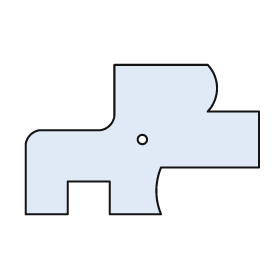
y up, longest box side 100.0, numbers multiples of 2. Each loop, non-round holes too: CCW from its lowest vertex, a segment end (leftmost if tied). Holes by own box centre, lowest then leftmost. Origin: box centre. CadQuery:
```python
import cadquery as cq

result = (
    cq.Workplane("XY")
    .moveTo(-50.0, -32.0)
    .lineTo(-32.0, -32.0)
    .lineTo(-32.0, -18.0)
    .lineTo(-14.0, -18.0)
    .lineTo(-14.0, -32.0)
    .lineTo(8.0, -32.0)
    .threePointArc((6.0, -22.0), (8.0, -12.0))
    .lineTo(50.0, -12.0)
    .lineTo(50.0, 12.0)
    .lineTo(28.0, 12.0)
    .threePointArc((32.0, 22.0), (28.0, 32.0))
    .lineTo(-12.0, 32.0)
    .lineTo(-12.0, 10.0)
    .threePointArc((-14.0, 6.0), (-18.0, 4.0))
    .lineTo(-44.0, 4.0)
    .threePointArc((-48.0, 2.0), (-50.0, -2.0))
    .close()
    .moveTo(0.0, 0.0)
    .circle(2.0)
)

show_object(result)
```